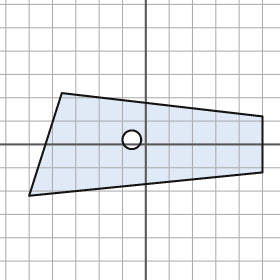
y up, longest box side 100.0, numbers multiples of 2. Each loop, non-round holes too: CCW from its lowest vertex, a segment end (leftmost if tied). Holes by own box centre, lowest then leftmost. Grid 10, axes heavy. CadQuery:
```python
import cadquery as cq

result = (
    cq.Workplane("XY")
    .moveTo(-50.0, -22.0)
    .lineTo(50.0, -12.0)
    .lineTo(50.0, 12.0)
    .lineTo(-36.0, 22.0)
    .close()
    .moveTo(-6.0, 2.0)
    .circle(4.0)
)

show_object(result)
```